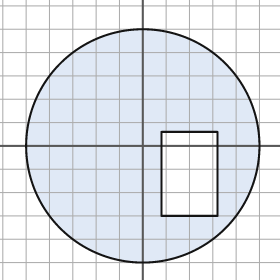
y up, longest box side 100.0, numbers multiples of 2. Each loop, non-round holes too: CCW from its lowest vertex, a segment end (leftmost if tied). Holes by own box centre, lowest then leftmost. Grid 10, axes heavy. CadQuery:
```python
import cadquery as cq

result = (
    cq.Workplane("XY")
    .moveTo(0.0, 0.0)
    .circle(50.0)
    .moveTo(8.0, -30.0)
    .lineTo(32.0, -30.0)
    .lineTo(32.0, 6.0)
    .lineTo(8.0, 6.0)
    .close()
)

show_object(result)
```